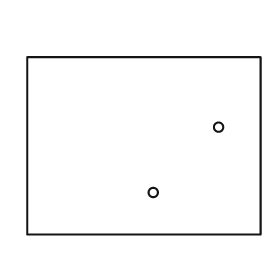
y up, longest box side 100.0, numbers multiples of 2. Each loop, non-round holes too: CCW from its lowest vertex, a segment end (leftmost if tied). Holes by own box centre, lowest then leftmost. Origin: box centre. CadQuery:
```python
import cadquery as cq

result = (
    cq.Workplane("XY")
    .moveTo(-50.0, -38.0)
    .lineTo(50.0, -38.0)
    .lineTo(50.0, 38.0)
    .lineTo(-50.0, 38.0)
    .close()
    .moveTo(4.0, -20.0)
    .circle(2.0)
    .moveTo(32.0, 8.0)
    .circle(2.0)
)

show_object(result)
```